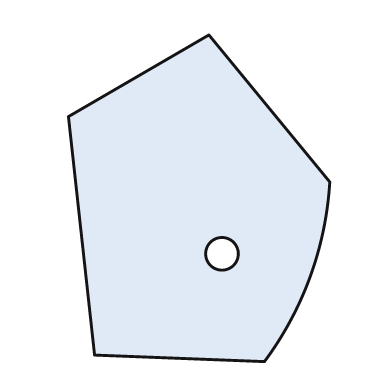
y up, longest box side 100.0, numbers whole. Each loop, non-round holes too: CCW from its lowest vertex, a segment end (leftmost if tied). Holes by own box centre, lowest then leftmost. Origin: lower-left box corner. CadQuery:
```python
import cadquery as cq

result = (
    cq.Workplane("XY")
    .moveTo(60.0, 0.0)
    .threePointArc((74.0, 26.0), (80.0, 55.0))
    .lineTo(43.0, 100.0)
    .lineTo(0.0, 75.0)
    .lineTo(8.0, 2.0)
    .close()
    .moveTo(47.0, 33.0)
    .circle(5.0)
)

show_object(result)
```